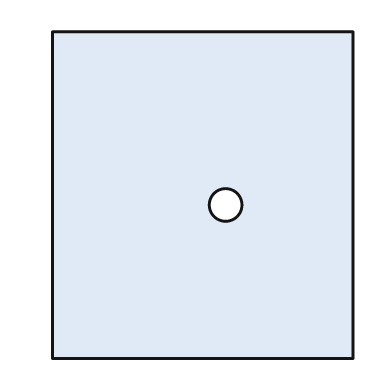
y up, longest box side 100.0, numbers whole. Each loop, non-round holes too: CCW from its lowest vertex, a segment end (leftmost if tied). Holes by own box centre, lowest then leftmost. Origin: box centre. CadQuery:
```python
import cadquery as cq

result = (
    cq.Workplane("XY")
    .moveTo(-46.0, -50.0)
    .lineTo(46.0, -50.0)
    .lineTo(46.0, 50.0)
    .lineTo(-46.0, 50.0)
    .close()
    .moveTo(7.0, -3.0)
    .circle(5.0)
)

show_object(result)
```